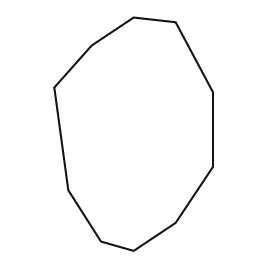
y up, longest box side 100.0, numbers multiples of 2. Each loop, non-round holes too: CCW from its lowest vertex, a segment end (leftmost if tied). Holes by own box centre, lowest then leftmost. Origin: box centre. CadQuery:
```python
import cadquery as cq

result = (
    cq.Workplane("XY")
    .moveTo(0.0, -50.0)
    .lineTo(18.0, -38.0)
    .lineTo(34.0, -14.0)
    .lineTo(34.0, 18.0)
    .lineTo(18.0, 48.0)
    .lineTo(0.0, 50.0)
    .lineTo(-18.0, 38.0)
    .lineTo(-34.0, 20.0)
    .lineTo(-28.0, -24.0)
    .lineTo(-14.0, -46.0)
    .close()
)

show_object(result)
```